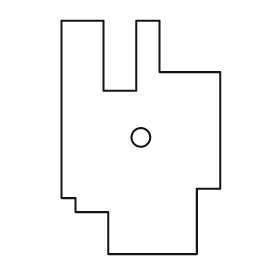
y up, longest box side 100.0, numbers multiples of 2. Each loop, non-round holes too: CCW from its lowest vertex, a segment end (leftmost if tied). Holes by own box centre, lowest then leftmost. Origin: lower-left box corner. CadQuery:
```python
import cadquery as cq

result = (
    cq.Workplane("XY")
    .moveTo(20.0, 0.0)
    .lineTo(58.0, 0.0)
    .lineTo(58.0, 28.0)
    .lineTo(68.0, 28.0)
    .lineTo(68.0, 78.0)
    .lineTo(42.0, 78.0)
    .lineTo(42.0, 100.0)
    .lineTo(32.0, 100.0)
    .lineTo(32.0, 70.0)
    .lineTo(18.0, 70.0)
    .lineTo(18.0, 100.0)
    .lineTo(0.0, 100.0)
    .lineTo(0.0, 24.0)
    .lineTo(6.0, 24.0)
    .lineTo(6.0, 18.0)
    .lineTo(20.0, 18.0)
    .close()
    .moveTo(34.0, 50.0)
    .circle(4.0)
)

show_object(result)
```